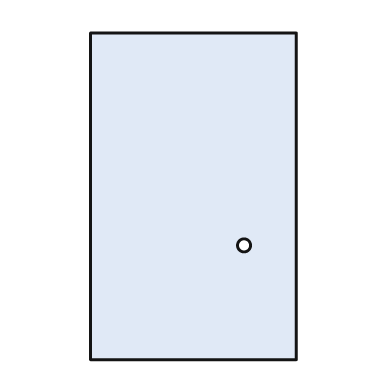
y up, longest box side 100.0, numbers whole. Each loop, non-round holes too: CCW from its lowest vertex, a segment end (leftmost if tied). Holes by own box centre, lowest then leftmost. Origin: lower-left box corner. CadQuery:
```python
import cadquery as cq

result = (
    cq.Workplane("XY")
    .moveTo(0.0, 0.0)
    .lineTo(63.0, 0.0)
    .lineTo(63.0, 100.0)
    .lineTo(0.0, 100.0)
    .close()
    .moveTo(47.0, 35.0)
    .circle(2.0)
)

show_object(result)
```